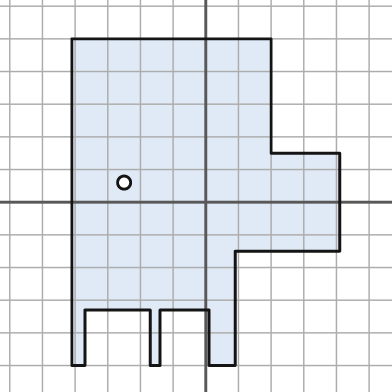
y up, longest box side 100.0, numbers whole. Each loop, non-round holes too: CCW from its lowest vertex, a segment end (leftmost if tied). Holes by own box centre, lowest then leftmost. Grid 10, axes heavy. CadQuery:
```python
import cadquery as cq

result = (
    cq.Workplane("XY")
    .moveTo(-41.0, -50.0)
    .lineTo(-37.0, -50.0)
    .lineTo(-37.0, -33.0)
    .lineTo(-17.0, -33.0)
    .lineTo(-17.0, -50.0)
    .lineTo(-14.0, -50.0)
    .lineTo(-14.0, -33.0)
    .lineTo(1.0, -33.0)
    .lineTo(1.0, -50.0)
    .lineTo(9.0, -50.0)
    .lineTo(9.0, -15.0)
    .lineTo(41.0, -15.0)
    .lineTo(41.0, 15.0)
    .lineTo(20.0, 15.0)
    .lineTo(20.0, 50.0)
    .lineTo(-41.0, 50.0)
    .close()
    .moveTo(-25.0, 6.0)
    .circle(2.0)
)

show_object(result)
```